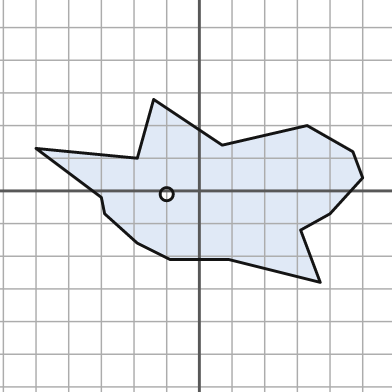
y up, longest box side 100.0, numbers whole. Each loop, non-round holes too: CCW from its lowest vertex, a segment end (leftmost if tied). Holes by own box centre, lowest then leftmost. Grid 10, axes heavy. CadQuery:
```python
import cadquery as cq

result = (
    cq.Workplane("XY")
    .moveTo(37.0, -28.0)
    .lineTo(31.0, -12.0)
    .lineTo(40.0, -7.0)
    .lineTo(50.0, 4.0)
    .lineTo(47.0, 12.0)
    .lineTo(33.0, 20.0)
    .lineTo(7.0, 14.0)
    .lineTo(-14.0, 28.0)
    .lineTo(-19.0, 10.0)
    .lineTo(-50.0, 13.0)
    .lineTo(-30.0, -2.0)
    .lineTo(-29.0, -7.0)
    .lineTo(-19.0, -16.0)
    .lineTo(-9.0, -21.0)
    .lineTo(9.0, -21.0)
    .close()
    .moveTo(-10.0, -1.0)
    .circle(2.0)
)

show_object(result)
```